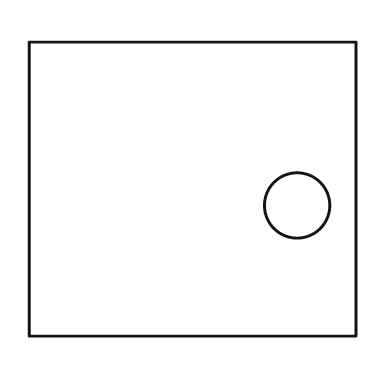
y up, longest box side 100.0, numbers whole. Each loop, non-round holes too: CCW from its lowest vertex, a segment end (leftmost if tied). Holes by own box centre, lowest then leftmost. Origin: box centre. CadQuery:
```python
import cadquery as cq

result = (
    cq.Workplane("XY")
    .moveTo(-50.0, -45.0)
    .lineTo(50.0, -45.0)
    .lineTo(50.0, 45.0)
    .lineTo(-50.0, 45.0)
    .close()
    .moveTo(32.0, -5.0)
    .circle(10.0)
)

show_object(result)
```